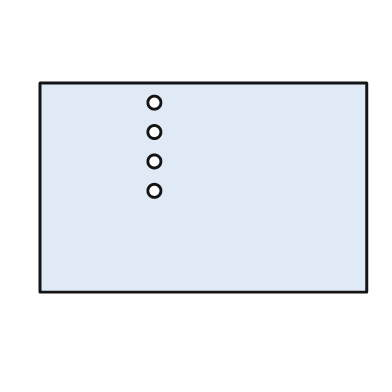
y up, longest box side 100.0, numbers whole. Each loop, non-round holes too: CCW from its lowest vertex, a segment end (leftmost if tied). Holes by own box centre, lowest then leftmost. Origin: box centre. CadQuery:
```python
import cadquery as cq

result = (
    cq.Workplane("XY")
    .moveTo(-50.0, -32.0)
    .lineTo(50.0, -32.0)
    .lineTo(50.0, 32.0)
    .lineTo(-50.0, 32.0)
    .close()
    .moveTo(-15.0, -1.0)
    .circle(2.0)
    .moveTo(-15.0, 8.0)
    .circle(2.0)
    .moveTo(-15.0, 17.0)
    .circle(2.0)
    .moveTo(-15.0, 26.0)
    .circle(2.0)
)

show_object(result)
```